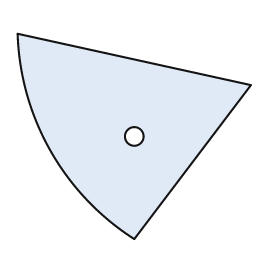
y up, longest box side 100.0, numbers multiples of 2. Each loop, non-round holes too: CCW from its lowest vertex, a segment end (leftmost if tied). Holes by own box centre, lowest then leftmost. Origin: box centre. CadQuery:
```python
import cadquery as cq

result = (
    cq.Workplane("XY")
    .moveTo(0.0, -44.0)
    .lineTo(50.0, 22.0)
    .lineTo(-50.0, 44.0)
    .threePointArc((-36.0, -6.0), (0.0, -44.0))
    .close()
    .moveTo(0.0, 0.0)
    .circle(4.0)
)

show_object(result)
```